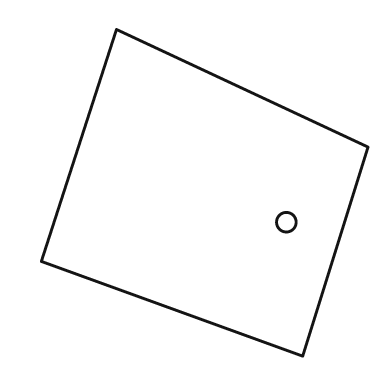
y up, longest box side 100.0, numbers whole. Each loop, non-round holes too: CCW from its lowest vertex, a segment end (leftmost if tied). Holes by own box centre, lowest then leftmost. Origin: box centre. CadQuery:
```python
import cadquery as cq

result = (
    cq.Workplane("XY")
    .moveTo(30.0, -50.0)
    .lineTo(50.0, 14.0)
    .lineTo(-27.0, 50.0)
    .lineTo(-50.0, -21.0)
    .close()
    .moveTo(25.0, -9.0)
    .circle(3.0)
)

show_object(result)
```